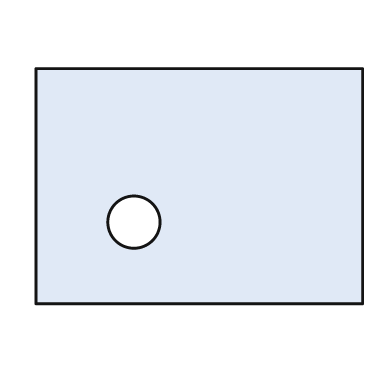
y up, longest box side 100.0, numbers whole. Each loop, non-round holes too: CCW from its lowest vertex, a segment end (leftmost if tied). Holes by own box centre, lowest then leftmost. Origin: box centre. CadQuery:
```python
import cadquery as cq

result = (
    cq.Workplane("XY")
    .moveTo(-50.0, -36.0)
    .lineTo(50.0, -36.0)
    .lineTo(50.0, 36.0)
    .lineTo(-50.0, 36.0)
    .close()
    .moveTo(-20.0, -11.0)
    .circle(8.0)
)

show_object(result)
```